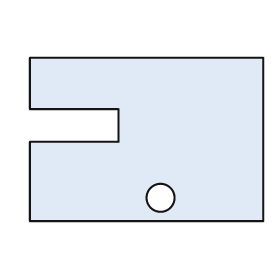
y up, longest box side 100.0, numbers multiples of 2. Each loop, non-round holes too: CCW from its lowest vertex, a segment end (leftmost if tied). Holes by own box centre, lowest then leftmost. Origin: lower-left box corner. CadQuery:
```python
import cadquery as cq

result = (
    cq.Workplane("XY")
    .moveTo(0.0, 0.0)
    .lineTo(100.0, 0.0)
    .lineTo(100.0, 70.0)
    .lineTo(0.0, 70.0)
    .lineTo(0.0, 48.0)
    .lineTo(38.0, 48.0)
    .lineTo(38.0, 34.0)
    .lineTo(0.0, 34.0)
    .close()
    .moveTo(56.0, 10.0)
    .circle(6.0)
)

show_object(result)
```